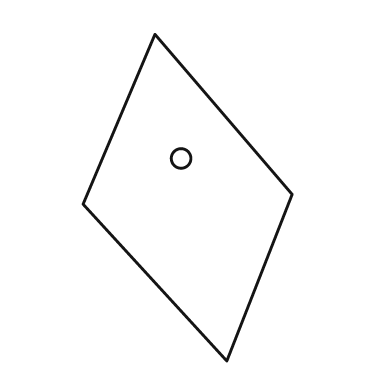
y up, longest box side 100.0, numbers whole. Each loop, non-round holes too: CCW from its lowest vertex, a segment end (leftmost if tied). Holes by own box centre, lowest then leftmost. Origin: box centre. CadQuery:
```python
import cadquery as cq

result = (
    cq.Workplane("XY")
    .moveTo(12.0, -50.0)
    .lineTo(32.0, 1.0)
    .lineTo(-10.0, 50.0)
    .lineTo(-32.0, -2.0)
    .close()
    .moveTo(-2.0, 12.0)
    .circle(3.0)
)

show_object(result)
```